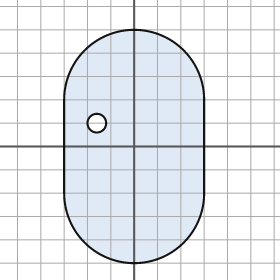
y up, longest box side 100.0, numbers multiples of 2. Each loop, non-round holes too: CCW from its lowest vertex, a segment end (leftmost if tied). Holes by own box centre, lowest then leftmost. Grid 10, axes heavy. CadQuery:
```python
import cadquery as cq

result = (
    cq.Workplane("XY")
    .moveTo(-30.0, -20.0)
    .threePointArc((0.0, -50.0), (30.0, -20.0))
    .lineTo(30.0, 20.0)
    .threePointArc((0.0, 50.0), (-30.0, 20.0))
    .close()
    .moveTo(-16.0, 10.0)
    .circle(4.0)
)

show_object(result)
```